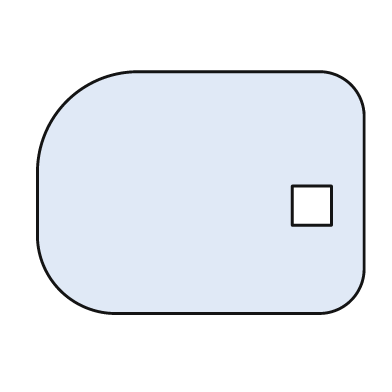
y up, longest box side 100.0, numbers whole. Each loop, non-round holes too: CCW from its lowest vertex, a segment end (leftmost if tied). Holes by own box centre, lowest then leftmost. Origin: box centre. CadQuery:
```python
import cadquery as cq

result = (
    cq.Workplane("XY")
    .moveTo(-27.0, -37.0)
    .lineTo(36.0, -37.0)
    .threePointArc((46.0, -33.0), (50.0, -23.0))
    .lineTo(50.0, 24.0)
    .threePointArc((46.0, 33.0), (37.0, 37.0))
    .lineTo(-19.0, 37.0)
    .threePointArc((-41.0, 28.0), (-50.0, 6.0))
    .lineTo(-50.0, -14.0)
    .threePointArc((-43.0, -30.0), (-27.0, -37.0))
    .close()
    .moveTo(28.0, -10.0)
    .lineTo(40.0, -10.0)
    .lineTo(40.0, 2.0)
    .lineTo(28.0, 2.0)
    .close()
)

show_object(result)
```